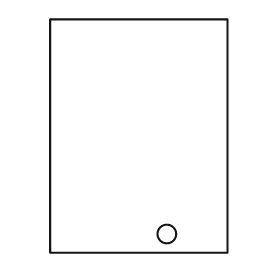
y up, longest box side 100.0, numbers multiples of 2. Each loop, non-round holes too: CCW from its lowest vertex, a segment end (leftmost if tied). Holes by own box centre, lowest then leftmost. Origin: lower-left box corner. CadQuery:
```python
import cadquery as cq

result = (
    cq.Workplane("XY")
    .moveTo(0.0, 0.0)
    .lineTo(76.0, 0.0)
    .lineTo(76.0, 100.0)
    .lineTo(0.0, 100.0)
    .close()
    .moveTo(50.0, 8.0)
    .circle(4.0)
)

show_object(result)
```